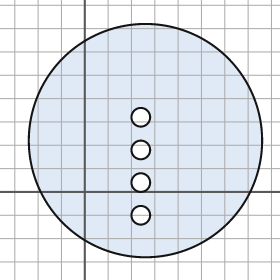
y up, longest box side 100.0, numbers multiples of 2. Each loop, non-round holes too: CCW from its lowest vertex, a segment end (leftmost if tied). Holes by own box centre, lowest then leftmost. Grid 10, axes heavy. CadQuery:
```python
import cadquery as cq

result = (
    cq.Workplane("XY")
    .moveTo(26.0, 22.0)
    .circle(50.0)
    .moveTo(24.0, -10.0)
    .circle(4.0)
    .moveTo(24.0, 4.0)
    .circle(4.0)
    .moveTo(24.0, 18.0)
    .circle(4.0)
    .moveTo(24.0, 32.0)
    .circle(4.0)
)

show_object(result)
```